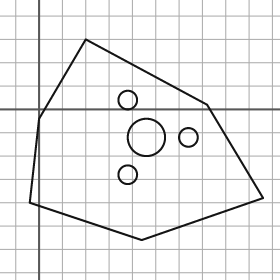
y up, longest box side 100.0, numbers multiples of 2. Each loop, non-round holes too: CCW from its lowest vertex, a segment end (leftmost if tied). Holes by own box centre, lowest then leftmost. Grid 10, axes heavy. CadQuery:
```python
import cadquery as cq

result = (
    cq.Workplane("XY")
    .moveTo(44.0, -56.0)
    .lineTo(96.0, -38.0)
    .lineTo(72.0, 2.0)
    .lineTo(20.0, 30.0)
    .lineTo(0.0, -4.0)
    .lineTo(-4.0, -40.0)
    .close()
    .moveTo(38.0, -28.0)
    .circle(4.0)
    .moveTo(46.0, -12.0)
    .circle(8.0)
    .moveTo(64.0, -12.0)
    .circle(4.0)
    .moveTo(38.0, 4.0)
    .circle(4.0)
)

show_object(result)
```